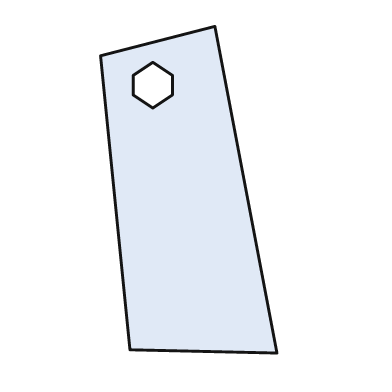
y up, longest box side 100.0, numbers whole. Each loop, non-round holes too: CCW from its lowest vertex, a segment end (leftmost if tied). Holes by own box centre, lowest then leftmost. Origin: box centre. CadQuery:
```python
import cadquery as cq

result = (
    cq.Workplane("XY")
    .moveTo(27.0, -50.0)
    .lineTo(8.0, 50.0)
    .lineTo(-27.0, 41.0)
    .lineTo(-18.0, -49.0)
    .close()
    .moveTo(-11.0, 25.0)
    .lineTo(-5.0, 29.0)
    .lineTo(-5.0, 35.0)
    .lineTo(-11.0, 39.0)
    .lineTo(-17.0, 35.0)
    .lineTo(-17.0, 29.0)
    .close()
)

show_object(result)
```